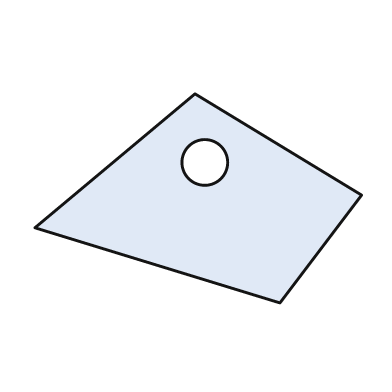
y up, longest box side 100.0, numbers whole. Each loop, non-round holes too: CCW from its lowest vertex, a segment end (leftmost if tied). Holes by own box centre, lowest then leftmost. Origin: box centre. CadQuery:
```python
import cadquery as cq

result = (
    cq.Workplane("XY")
    .moveTo(25.0, -32.0)
    .lineTo(50.0, 1.0)
    .lineTo(-1.0, 32.0)
    .lineTo(-50.0, -9.0)
    .close()
    .moveTo(2.0, 11.0)
    .circle(7.0)
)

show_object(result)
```